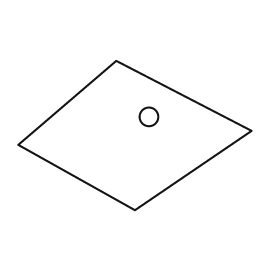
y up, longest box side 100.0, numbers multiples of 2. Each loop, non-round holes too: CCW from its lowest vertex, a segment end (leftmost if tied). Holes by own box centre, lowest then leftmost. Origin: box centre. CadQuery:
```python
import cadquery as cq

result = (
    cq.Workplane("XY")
    .moveTo(0.0, -32.0)
    .lineTo(50.0, 2.0)
    .lineTo(-8.0, 32.0)
    .lineTo(-50.0, -4.0)
    .close()
    .moveTo(6.0, 8.0)
    .circle(4.0)
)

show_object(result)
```